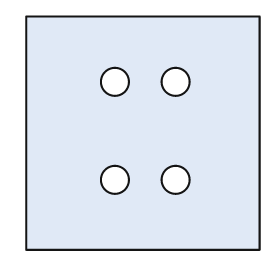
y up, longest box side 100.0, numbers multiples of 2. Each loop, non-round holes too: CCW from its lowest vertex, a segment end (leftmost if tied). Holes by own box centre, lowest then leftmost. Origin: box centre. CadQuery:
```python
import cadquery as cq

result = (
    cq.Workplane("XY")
    .moveTo(-50.0, -50.0)
    .lineTo(50.0, -50.0)
    .lineTo(50.0, 50.0)
    .lineTo(-50.0, 50.0)
    .close()
    .moveTo(-12.0, -20.0)
    .circle(6.0)
    .moveTo(14.0, -20.0)
    .circle(6.0)
    .moveTo(-12.0, 22.0)
    .circle(6.0)
    .moveTo(14.0, 22.0)
    .circle(6.0)
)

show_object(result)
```